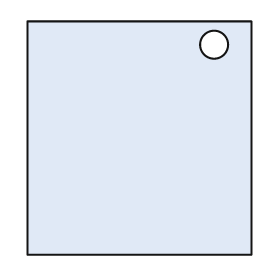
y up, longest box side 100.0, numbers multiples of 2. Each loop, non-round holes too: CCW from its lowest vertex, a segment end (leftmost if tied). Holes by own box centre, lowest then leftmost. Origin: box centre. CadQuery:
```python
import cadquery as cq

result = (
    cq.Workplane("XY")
    .moveTo(-48.0, -50.0)
    .lineTo(48.0, -50.0)
    .lineTo(48.0, 50.0)
    .lineTo(-48.0, 50.0)
    .close()
    .moveTo(32.0, 40.0)
    .circle(6.0)
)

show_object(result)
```